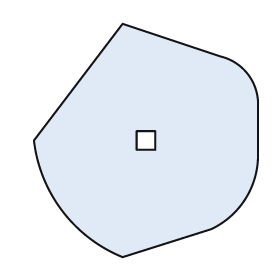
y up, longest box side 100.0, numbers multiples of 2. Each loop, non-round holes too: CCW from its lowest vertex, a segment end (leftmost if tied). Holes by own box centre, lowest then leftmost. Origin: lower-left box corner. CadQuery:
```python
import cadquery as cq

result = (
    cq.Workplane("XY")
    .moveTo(38.0, 0.0)
    .lineTo(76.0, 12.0)
    .threePointArc((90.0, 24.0), (96.0, 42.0))
    .lineTo(96.0, 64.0)
    .threePointArc((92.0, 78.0), (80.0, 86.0))
    .lineTo(38.0, 100.0)
    .lineTo(0.0, 50.0)
    .threePointArc((12.0, 20.0), (38.0, 0.0))
    .close()
    .moveTo(44.0, 46.0)
    .lineTo(52.0, 46.0)
    .lineTo(52.0, 54.0)
    .lineTo(44.0, 54.0)
    .close()
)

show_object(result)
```